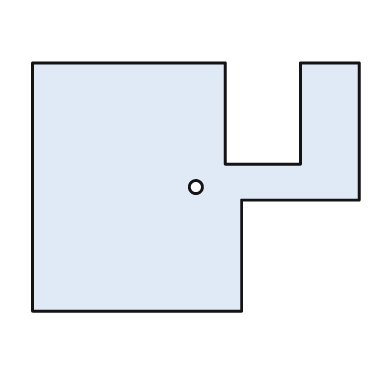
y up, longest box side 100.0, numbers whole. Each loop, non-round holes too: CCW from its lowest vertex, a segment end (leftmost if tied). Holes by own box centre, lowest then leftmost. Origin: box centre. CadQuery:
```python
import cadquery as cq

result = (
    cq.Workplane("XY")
    .moveTo(-50.0, -38.0)
    .lineTo(14.0, -38.0)
    .lineTo(14.0, -4.0)
    .lineTo(50.0, -4.0)
    .lineTo(50.0, 38.0)
    .lineTo(32.0, 38.0)
    .lineTo(32.0, 7.0)
    .lineTo(9.0, 7.0)
    .lineTo(9.0, 38.0)
    .lineTo(-50.0, 38.0)
    .close()
    .moveTo(0.0, 0.0)
    .circle(2.0)
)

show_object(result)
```